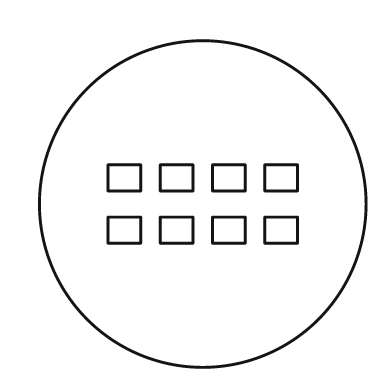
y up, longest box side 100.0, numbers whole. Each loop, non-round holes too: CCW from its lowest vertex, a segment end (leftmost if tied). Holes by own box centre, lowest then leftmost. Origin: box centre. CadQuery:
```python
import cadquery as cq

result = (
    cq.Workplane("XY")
    .moveTo(0.0, 0.0)
    .circle(50.0)
    .moveTo(-29.0, -12.0)
    .lineTo(-19.0, -12.0)
    .lineTo(-19.0, -4.0)
    .lineTo(-29.0, -4.0)
    .close()
    .moveTo(-13.0, -12.0)
    .lineTo(-3.0, -12.0)
    .lineTo(-3.0, -4.0)
    .lineTo(-13.0, -4.0)
    .close()
    .moveTo(3.0, -12.0)
    .lineTo(13.0, -12.0)
    .lineTo(13.0, -4.0)
    .lineTo(3.0, -4.0)
    .close()
    .moveTo(19.0, -12.0)
    .lineTo(29.0, -12.0)
    .lineTo(29.0, -4.0)
    .lineTo(19.0, -4.0)
    .close()
    .moveTo(-29.0, 4.0)
    .lineTo(-19.0, 4.0)
    .lineTo(-19.0, 12.0)
    .lineTo(-29.0, 12.0)
    .close()
    .moveTo(-13.0, 4.0)
    .lineTo(-3.0, 4.0)
    .lineTo(-3.0, 12.0)
    .lineTo(-13.0, 12.0)
    .close()
    .moveTo(3.0, 4.0)
    .lineTo(13.0, 4.0)
    .lineTo(13.0, 12.0)
    .lineTo(3.0, 12.0)
    .close()
    .moveTo(19.0, 4.0)
    .lineTo(29.0, 4.0)
    .lineTo(29.0, 12.0)
    .lineTo(19.0, 12.0)
    .close()
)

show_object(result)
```